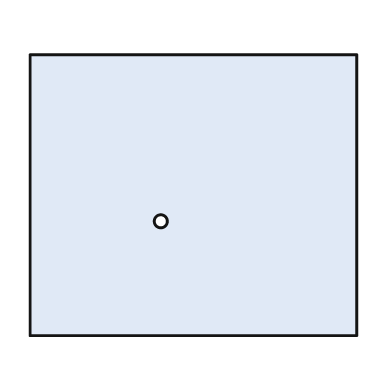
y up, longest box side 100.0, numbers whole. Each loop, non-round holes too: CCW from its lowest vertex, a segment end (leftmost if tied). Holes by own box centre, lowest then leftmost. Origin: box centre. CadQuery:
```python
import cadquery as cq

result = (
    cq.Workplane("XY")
    .moveTo(-50.0, -43.0)
    .lineTo(50.0, -43.0)
    .lineTo(50.0, 43.0)
    .lineTo(-50.0, 43.0)
    .close()
    .moveTo(-10.0, -8.0)
    .circle(2.0)
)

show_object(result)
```